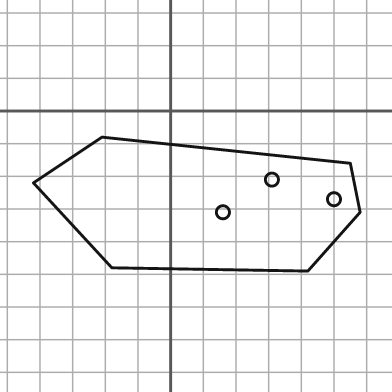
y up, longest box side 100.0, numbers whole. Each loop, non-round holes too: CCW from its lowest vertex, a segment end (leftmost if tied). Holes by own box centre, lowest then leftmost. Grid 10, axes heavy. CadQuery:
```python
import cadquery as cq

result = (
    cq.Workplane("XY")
    .moveTo(42.0, -49.0)
    .lineTo(58.0, -31.0)
    .lineTo(55.0, -16.0)
    .lineTo(-21.0, -8.0)
    .lineTo(-42.0, -22.0)
    .lineTo(-18.0, -48.0)
    .close()
    .moveTo(16.0, -31.0)
    .circle(2.0)
    .moveTo(50.0, -27.0)
    .circle(2.0)
    .moveTo(31.0, -21.0)
    .circle(2.0)
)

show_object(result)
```